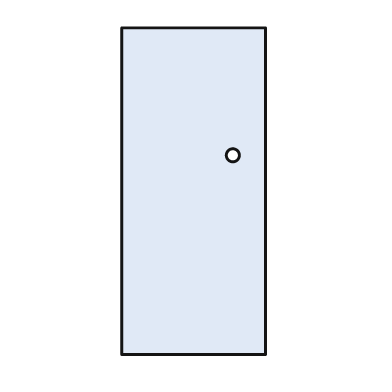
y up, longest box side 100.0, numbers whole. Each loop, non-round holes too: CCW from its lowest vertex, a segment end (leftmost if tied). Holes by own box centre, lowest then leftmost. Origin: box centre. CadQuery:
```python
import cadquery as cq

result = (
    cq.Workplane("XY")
    .moveTo(-22.0, -50.0)
    .lineTo(22.0, -50.0)
    .lineTo(22.0, 50.0)
    .lineTo(-22.0, 50.0)
    .close()
    .moveTo(12.0, 11.0)
    .circle(2.0)
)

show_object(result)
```